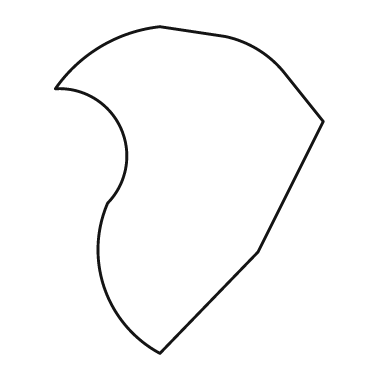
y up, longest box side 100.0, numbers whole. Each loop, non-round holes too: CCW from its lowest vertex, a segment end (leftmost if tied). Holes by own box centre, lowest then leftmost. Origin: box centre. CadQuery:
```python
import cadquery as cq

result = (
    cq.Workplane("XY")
    .moveTo(-9.0, -50.0)
    .lineTo(21.0, -19.0)
    .lineTo(41.0, 21.0)
    .lineTo(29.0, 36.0)
    .threePointArc((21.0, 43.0), (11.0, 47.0))
    .lineTo(-9.0, 50.0)
    .threePointArc((-27.0, 44.0), (-41.0, 31.0))
    .threePointArc((-21.0, 19.0), (-25.0, -4.0))
    .threePointArc((-26.0, -30.0), (-9.0, -50.0))
    .close()
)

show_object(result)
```